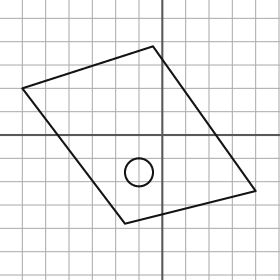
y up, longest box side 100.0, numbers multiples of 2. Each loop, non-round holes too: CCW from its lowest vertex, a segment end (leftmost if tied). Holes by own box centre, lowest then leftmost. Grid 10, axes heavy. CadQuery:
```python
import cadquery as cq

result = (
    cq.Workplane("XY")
    .moveTo(-16.0, -38.0)
    .lineTo(40.0, -24.0)
    .lineTo(-4.0, 38.0)
    .lineTo(-60.0, 20.0)
    .close()
    .moveTo(-10.0, -16.0)
    .circle(6.0)
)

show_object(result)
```